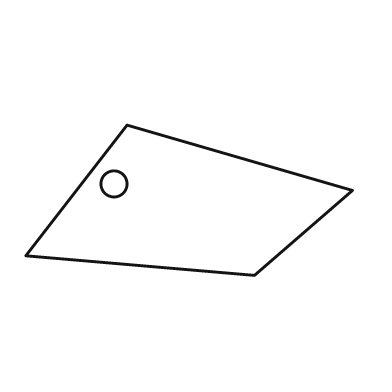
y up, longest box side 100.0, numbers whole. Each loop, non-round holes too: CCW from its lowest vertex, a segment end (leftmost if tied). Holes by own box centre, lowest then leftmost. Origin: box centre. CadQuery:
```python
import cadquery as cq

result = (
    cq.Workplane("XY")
    .moveTo(20.0, -23.0)
    .lineTo(50.0, 3.0)
    .lineTo(-19.0, 23.0)
    .lineTo(-50.0, -17.0)
    .close()
    .moveTo(-23.0, 5.0)
    .circle(4.0)
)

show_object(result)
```